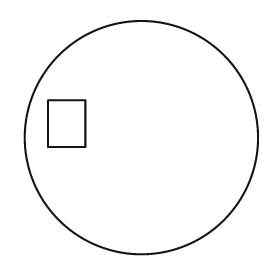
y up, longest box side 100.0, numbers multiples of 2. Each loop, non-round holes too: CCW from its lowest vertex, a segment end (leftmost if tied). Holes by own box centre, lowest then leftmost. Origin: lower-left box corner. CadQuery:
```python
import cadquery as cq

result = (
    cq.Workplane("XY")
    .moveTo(50.0, 50.0)
    .circle(50.0)
    .moveTo(10.0, 46.0)
    .lineTo(26.0, 46.0)
    .lineTo(26.0, 66.0)
    .lineTo(10.0, 66.0)
    .close()
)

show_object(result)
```